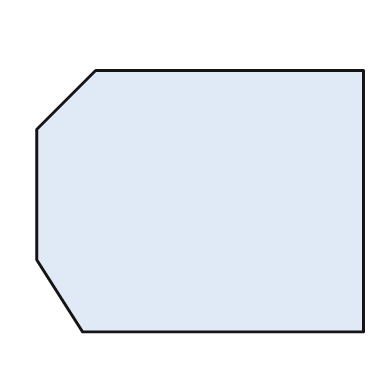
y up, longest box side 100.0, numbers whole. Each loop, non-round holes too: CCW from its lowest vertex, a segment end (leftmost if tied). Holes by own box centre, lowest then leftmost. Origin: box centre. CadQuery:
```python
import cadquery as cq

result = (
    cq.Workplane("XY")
    .moveTo(-36.0, -40.0)
    .lineTo(50.0, -40.0)
    .lineTo(50.0, 40.0)
    .lineTo(-32.0, 40.0)
    .lineTo(-50.0, 22.0)
    .lineTo(-50.0, -18.0)
    .close()
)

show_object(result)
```